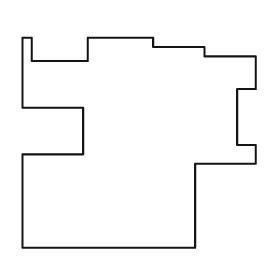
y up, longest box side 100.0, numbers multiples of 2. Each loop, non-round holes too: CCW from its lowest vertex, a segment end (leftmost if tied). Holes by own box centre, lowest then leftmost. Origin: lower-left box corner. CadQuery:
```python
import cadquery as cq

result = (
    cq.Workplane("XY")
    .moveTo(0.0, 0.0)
    .lineTo(74.0, 0.0)
    .lineTo(74.0, 36.0)
    .lineTo(100.0, 36.0)
    .lineTo(100.0, 44.0)
    .lineTo(92.0, 44.0)
    .lineTo(92.0, 68.0)
    .lineTo(100.0, 68.0)
    .lineTo(100.0, 82.0)
    .lineTo(78.0, 82.0)
    .lineTo(78.0, 86.0)
    .lineTo(56.0, 86.0)
    .lineTo(56.0, 90.0)
    .lineTo(28.0, 90.0)
    .lineTo(28.0, 80.0)
    .lineTo(4.0, 80.0)
    .lineTo(4.0, 90.0)
    .lineTo(0.0, 90.0)
    .lineTo(0.0, 60.0)
    .lineTo(26.0, 60.0)
    .lineTo(26.0, 40.0)
    .lineTo(0.0, 40.0)
    .close()
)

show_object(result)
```